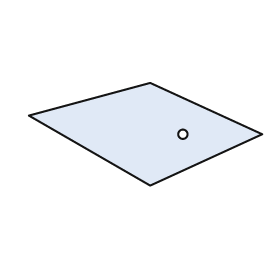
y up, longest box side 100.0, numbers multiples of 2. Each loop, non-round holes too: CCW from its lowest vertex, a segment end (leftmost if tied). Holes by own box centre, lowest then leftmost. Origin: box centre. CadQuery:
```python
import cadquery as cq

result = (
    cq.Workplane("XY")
    .moveTo(2.0, -22.0)
    .lineTo(50.0, 0.0)
    .lineTo(2.0, 22.0)
    .lineTo(-50.0, 8.0)
    .close()
    .moveTo(16.0, 0.0)
    .circle(2.0)
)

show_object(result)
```